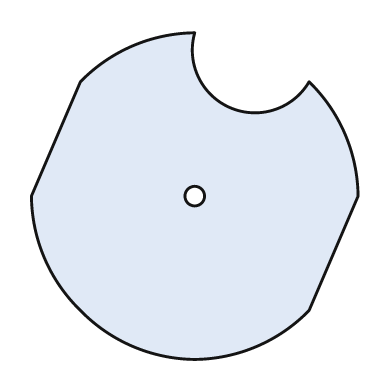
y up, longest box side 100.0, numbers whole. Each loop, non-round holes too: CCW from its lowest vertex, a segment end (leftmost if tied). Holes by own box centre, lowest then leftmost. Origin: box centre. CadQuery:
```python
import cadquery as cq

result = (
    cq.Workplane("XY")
    .moveTo(0.0, -50.0)
    .threePointArc((19.0, -46.0), (35.0, -35.0))
    .lineTo(50.0, 0.0)
    .threePointArc((46.0, 19.0), (35.0, 35.0))
    .threePointArc((11.0, 27.0), (0.0, 50.0))
    .threePointArc((-19.0, 46.0), (-35.0, 35.0))
    .lineTo(-50.0, 0.0)
    .threePointArc((-46.0, -19.0), (-35.0, -35.0))
    .threePointArc((-19.0, -46.0), (0.0, -50.0))
    .close()
    .moveTo(0.0, 0.0)
    .circle(3.0)
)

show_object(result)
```